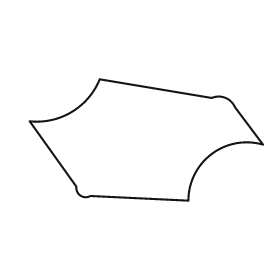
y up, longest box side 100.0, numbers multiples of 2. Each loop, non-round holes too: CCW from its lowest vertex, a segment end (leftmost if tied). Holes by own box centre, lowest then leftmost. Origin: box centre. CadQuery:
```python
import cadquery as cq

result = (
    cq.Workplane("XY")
    .moveTo(18.0, -26.0)
    .threePointArc((28.0, -6.0), (50.0, -2.0))
    .lineTo(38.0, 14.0)
    .threePointArc((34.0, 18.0), (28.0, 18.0))
    .lineTo(-20.0, 26.0)
    .threePointArc((-32.0, 12.0), (-50.0, 8.0))
    .lineTo(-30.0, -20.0)
    .threePointArc((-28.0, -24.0), (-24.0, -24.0))
    .close()
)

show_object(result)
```